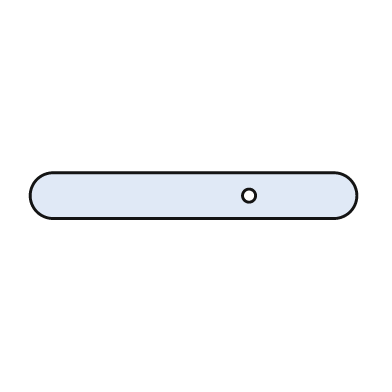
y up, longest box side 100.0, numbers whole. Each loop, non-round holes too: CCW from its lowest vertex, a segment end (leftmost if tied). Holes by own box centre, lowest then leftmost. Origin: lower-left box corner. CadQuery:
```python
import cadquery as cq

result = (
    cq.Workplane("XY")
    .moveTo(7.0, 0.0)
    .lineTo(93.0, 0.0)
    .threePointArc((100.0, 7.0), (93.0, 14.0))
    .lineTo(7.0, 14.0)
    .threePointArc((0.0, 7.0), (7.0, 0.0))
    .close()
    .moveTo(67.0, 7.0)
    .circle(2.0)
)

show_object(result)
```